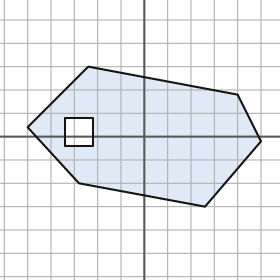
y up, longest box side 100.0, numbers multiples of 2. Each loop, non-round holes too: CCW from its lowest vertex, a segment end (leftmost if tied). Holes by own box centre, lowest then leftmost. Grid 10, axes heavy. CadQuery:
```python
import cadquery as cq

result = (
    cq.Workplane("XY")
    .moveTo(26.0, -30.0)
    .lineTo(50.0, -2.0)
    .lineTo(40.0, 18.0)
    .lineTo(-24.0, 30.0)
    .lineTo(-50.0, 4.0)
    .lineTo(-28.0, -20.0)
    .close()
    .moveTo(-34.0, -4.0)
    .lineTo(-22.0, -4.0)
    .lineTo(-22.0, 8.0)
    .lineTo(-34.0, 8.0)
    .close()
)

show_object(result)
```